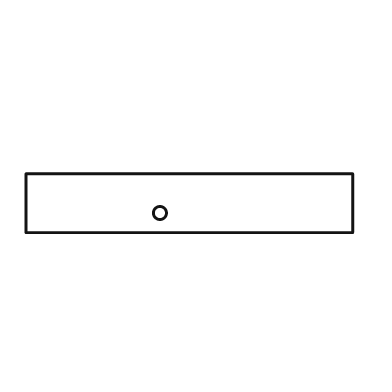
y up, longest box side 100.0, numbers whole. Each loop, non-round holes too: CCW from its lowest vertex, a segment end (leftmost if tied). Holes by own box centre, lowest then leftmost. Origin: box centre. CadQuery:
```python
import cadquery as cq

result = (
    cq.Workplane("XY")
    .moveTo(-50.0, -9.0)
    .lineTo(50.0, -9.0)
    .lineTo(50.0, 9.0)
    .lineTo(-50.0, 9.0)
    .close()
    .moveTo(-9.0, -3.0)
    .circle(2.0)
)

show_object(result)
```